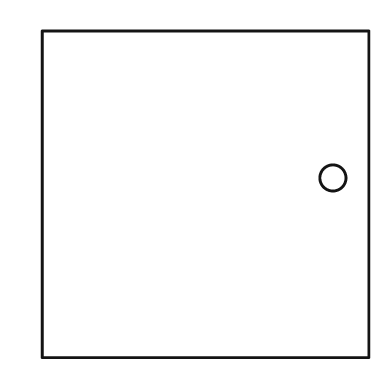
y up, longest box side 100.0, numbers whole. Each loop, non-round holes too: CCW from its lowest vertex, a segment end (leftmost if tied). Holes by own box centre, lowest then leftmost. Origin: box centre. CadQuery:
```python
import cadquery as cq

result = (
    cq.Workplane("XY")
    .moveTo(-50.0, -50.0)
    .lineTo(50.0, -50.0)
    .lineTo(50.0, 50.0)
    .lineTo(-50.0, 50.0)
    .close()
    .moveTo(39.0, 5.0)
    .circle(4.0)
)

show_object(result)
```